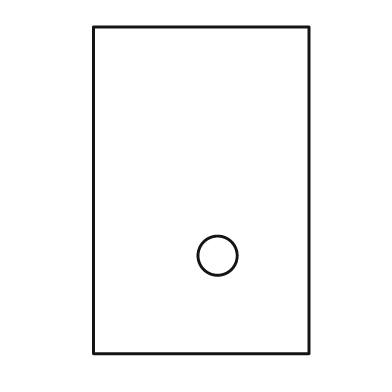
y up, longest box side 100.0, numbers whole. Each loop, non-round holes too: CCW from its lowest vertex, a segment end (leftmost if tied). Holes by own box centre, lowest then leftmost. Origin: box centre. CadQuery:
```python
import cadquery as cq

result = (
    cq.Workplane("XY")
    .moveTo(-33.0, -50.0)
    .lineTo(33.0, -50.0)
    .lineTo(33.0, 50.0)
    .lineTo(-33.0, 50.0)
    .close()
    .moveTo(5.0, -20.0)
    .circle(6.0)
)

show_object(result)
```